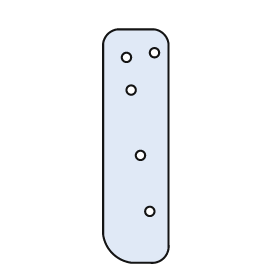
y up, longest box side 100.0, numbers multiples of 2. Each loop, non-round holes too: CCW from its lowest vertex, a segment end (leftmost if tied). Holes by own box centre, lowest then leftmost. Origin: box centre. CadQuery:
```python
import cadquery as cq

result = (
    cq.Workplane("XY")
    .moveTo(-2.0, -50.0)
    .lineTo(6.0, -50.0)
    .threePointArc((12.0, -48.0), (14.0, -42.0))
    .lineTo(14.0, 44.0)
    .threePointArc((12.0, 48.0), (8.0, 50.0))
    .lineTo(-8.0, 50.0)
    .threePointArc((-12.0, 48.0), (-14.0, 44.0))
    .lineTo(-14.0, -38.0)
    .threePointArc((-10.0, -46.0), (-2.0, -50.0))
    .close()
    .moveTo(6.0, -28.0)
    .circle(2.0)
    .moveTo(2.0, -4.0)
    .circle(2.0)
    .moveTo(-2.0, 24.0)
    .circle(2.0)
    .moveTo(-4.0, 38.0)
    .circle(2.0)
    .moveTo(8.0, 40.0)
    .circle(2.0)
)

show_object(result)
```